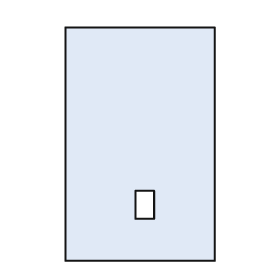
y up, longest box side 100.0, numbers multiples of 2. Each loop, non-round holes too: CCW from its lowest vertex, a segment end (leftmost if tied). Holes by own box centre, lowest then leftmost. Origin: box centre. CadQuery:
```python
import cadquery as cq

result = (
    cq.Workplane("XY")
    .moveTo(-32.0, -50.0)
    .lineTo(32.0, -50.0)
    .lineTo(32.0, 50.0)
    .lineTo(-32.0, 50.0)
    .close()
    .moveTo(-2.0, -32.0)
    .lineTo(6.0, -32.0)
    .lineTo(6.0, -20.0)
    .lineTo(-2.0, -20.0)
    .close()
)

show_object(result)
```